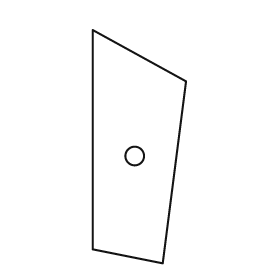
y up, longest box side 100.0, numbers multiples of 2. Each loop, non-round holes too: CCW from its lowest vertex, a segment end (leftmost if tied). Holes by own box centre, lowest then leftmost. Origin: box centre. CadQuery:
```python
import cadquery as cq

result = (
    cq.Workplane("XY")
    .moveTo(10.0, -50.0)
    .lineTo(20.0, 28.0)
    .lineTo(-20.0, 50.0)
    .lineTo(-20.0, -44.0)
    .close()
    .moveTo(-2.0, -4.0)
    .circle(4.0)
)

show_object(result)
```